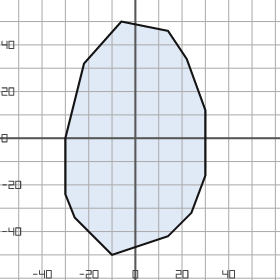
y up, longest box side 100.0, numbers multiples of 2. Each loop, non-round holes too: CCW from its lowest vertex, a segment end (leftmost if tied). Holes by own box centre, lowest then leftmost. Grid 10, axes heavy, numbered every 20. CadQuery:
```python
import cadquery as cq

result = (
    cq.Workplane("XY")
    .moveTo(-10.0, -50.0)
    .lineTo(14.0, -42.0)
    .lineTo(24.0, -32.0)
    .lineTo(30.0, -16.0)
    .lineTo(30.0, 12.0)
    .lineTo(22.0, 34.0)
    .lineTo(14.0, 46.0)
    .lineTo(-6.0, 50.0)
    .lineTo(-22.0, 32.0)
    .lineTo(-30.0, 0.0)
    .lineTo(-30.0, -24.0)
    .lineTo(-26.0, -34.0)
    .close()
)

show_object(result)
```